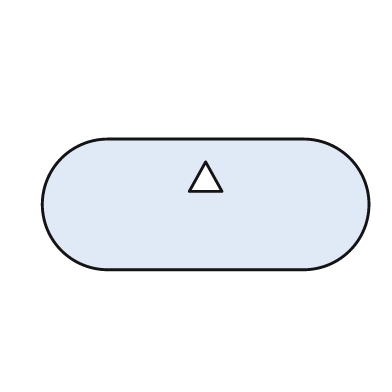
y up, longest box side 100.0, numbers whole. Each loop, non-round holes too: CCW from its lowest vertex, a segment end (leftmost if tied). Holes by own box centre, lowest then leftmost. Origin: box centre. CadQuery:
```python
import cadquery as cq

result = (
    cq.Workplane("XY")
    .moveTo(-30.0, -20.0)
    .lineTo(30.0, -20.0)
    .threePointArc((50.0, 0.0), (30.0, 20.0))
    .lineTo(-30.0, 20.0)
    .threePointArc((-50.0, 0.0), (-30.0, -20.0))
    .close()
    .moveTo(-5.0, 4.0)
    .lineTo(5.0, 4.0)
    .lineTo(0.0, 13.0)
    .close()
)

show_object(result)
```